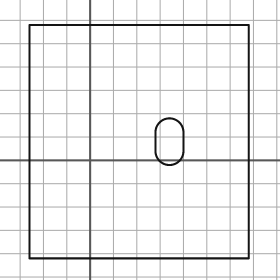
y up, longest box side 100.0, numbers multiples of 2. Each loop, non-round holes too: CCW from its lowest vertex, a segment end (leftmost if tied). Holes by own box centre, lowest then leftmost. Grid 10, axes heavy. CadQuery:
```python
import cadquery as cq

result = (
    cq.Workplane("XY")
    .moveTo(-26.0, -42.0)
    .lineTo(68.0, -42.0)
    .lineTo(68.0, 58.0)
    .lineTo(-26.0, 58.0)
    .close()
    .moveTo(28.0, 4.0)
    .threePointArc((34.0, -2.0), (40.0, 4.0))
    .lineTo(40.0, 12.0)
    .threePointArc((34.0, 18.0), (28.0, 12.0))
    .close()
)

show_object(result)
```